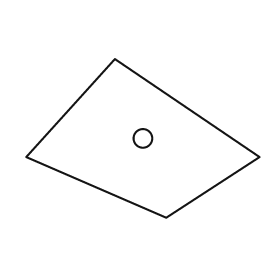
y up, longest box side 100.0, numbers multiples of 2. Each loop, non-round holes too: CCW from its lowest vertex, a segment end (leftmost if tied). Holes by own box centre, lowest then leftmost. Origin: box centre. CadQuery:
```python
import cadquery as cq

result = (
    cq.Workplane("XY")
    .moveTo(10.0, -34.0)
    .lineTo(50.0, -8.0)
    .lineTo(-12.0, 34.0)
    .lineTo(-50.0, -8.0)
    .close()
    .moveTo(0.0, 0.0)
    .circle(4.0)
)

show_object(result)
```